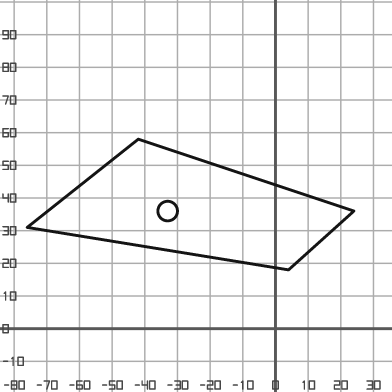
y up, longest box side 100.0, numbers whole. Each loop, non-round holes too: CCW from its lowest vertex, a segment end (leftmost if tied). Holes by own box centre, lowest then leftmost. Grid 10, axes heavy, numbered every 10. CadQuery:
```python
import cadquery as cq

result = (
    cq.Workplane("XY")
    .moveTo(4.0, 18.0)
    .lineTo(24.0, 36.0)
    .lineTo(-42.0, 58.0)
    .lineTo(-76.0, 31.0)
    .close()
    .moveTo(-33.0, 36.0)
    .circle(3.0)
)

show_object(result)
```